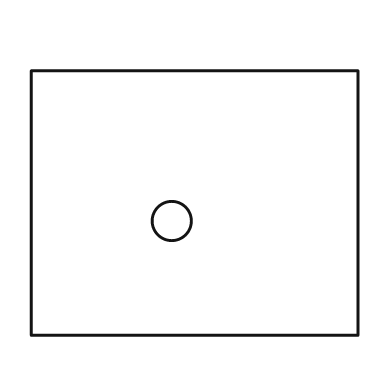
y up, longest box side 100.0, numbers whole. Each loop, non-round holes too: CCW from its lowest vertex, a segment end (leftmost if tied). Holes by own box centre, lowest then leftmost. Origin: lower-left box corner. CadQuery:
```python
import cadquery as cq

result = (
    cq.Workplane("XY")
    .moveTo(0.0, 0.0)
    .lineTo(100.0, 0.0)
    .lineTo(100.0, 81.0)
    .lineTo(0.0, 81.0)
    .close()
    .moveTo(43.0, 35.0)
    .circle(6.0)
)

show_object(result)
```